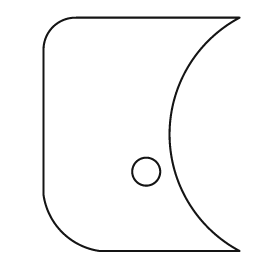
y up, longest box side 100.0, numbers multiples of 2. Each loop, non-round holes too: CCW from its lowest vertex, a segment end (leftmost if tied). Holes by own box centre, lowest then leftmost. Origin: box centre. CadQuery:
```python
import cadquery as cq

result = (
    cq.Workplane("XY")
    .moveTo(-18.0, -50.0)
    .lineTo(42.0, -50.0)
    .threePointArc((12.0, 0.0), (42.0, 50.0))
    .lineTo(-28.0, 50.0)
    .threePointArc((-38.0, 46.0), (-42.0, 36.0))
    .lineTo(-42.0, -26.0)
    .threePointArc((-34.0, -42.0), (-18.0, -50.0))
    .close()
    .moveTo(2.0, -16.0)
    .circle(6.0)
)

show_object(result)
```